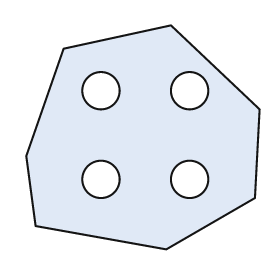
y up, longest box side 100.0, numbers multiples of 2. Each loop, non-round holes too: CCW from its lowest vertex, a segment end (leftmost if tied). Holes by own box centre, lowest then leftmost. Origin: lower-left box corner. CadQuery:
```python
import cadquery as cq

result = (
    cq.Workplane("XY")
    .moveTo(60.0, 0.0)
    .lineTo(98.0, 22.0)
    .lineTo(100.0, 60.0)
    .lineTo(62.0, 96.0)
    .lineTo(16.0, 86.0)
    .lineTo(0.0, 40.0)
    .lineTo(4.0, 10.0)
    .close()
    .moveTo(32.0, 30.0)
    .circle(8.0)
    .moveTo(70.0, 30.0)
    .circle(8.0)
    .moveTo(32.0, 68.0)
    .circle(8.0)
    .moveTo(70.0, 68.0)
    .circle(8.0)
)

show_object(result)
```